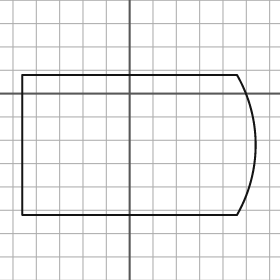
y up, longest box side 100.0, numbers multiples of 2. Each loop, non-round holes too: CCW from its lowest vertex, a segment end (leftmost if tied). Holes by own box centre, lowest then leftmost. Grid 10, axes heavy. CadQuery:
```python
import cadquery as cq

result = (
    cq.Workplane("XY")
    .moveTo(-46.0, -52.0)
    .lineTo(46.0, -52.0)
    .threePointArc((54.0, -22.0), (46.0, 8.0))
    .lineTo(-46.0, 8.0)
    .close()
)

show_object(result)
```